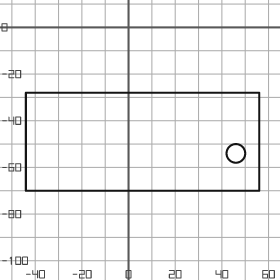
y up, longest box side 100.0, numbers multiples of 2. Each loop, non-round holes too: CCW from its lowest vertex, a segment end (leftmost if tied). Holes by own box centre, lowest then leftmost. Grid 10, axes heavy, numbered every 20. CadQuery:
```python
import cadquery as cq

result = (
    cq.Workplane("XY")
    .moveTo(-44.0, -70.0)
    .lineTo(56.0, -70.0)
    .lineTo(56.0, -28.0)
    .lineTo(-44.0, -28.0)
    .close()
    .moveTo(46.0, -54.0)
    .circle(4.0)
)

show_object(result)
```